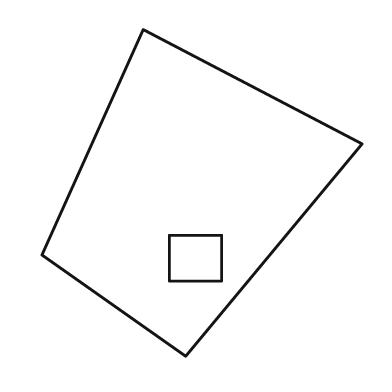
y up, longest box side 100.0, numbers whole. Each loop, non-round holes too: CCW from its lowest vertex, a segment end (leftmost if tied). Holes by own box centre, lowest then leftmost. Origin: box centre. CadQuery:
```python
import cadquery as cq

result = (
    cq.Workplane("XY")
    .moveTo(-5.0, -50.0)
    .lineTo(49.0, 15.0)
    .lineTo(-18.0, 50.0)
    .lineTo(-49.0, -19.0)
    .close()
    .moveTo(-10.0, -27.0)
    .lineTo(6.0, -27.0)
    .lineTo(6.0, -13.0)
    .lineTo(-10.0, -13.0)
    .close()
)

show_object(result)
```